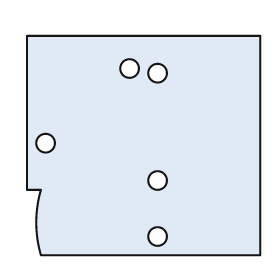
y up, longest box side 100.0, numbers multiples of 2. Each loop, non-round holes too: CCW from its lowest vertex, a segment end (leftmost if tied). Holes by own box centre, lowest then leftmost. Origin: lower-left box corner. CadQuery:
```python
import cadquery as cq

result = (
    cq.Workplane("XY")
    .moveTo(6.0, 0.0)
    .lineTo(100.0, 0.0)
    .lineTo(100.0, 94.0)
    .lineTo(0.0, 94.0)
    .lineTo(0.0, 28.0)
    .lineTo(6.0, 28.0)
    .threePointArc((4.0, 14.0), (6.0, 0.0))
    .close()
    .moveTo(56.0, 8.0)
    .circle(4.0)
    .moveTo(56.0, 32.0)
    .circle(4.0)
    .moveTo(8.0, 48.0)
    .circle(4.0)
    .moveTo(56.0, 78.0)
    .circle(4.0)
    .moveTo(44.0, 80.0)
    .circle(4.0)
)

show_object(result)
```